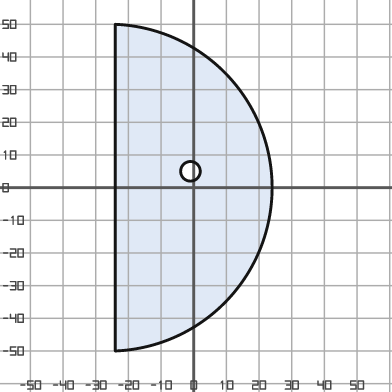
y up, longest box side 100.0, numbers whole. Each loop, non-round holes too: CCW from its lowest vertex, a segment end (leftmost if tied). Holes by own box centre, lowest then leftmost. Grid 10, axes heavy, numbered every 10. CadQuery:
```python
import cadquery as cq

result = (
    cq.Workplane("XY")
    .moveTo(-24.0, -50.0)
    .threePointArc((24.0, 0.0), (-24.0, 50.0))
    .close()
    .moveTo(-1.0, 5.0)
    .circle(3.0)
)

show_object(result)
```